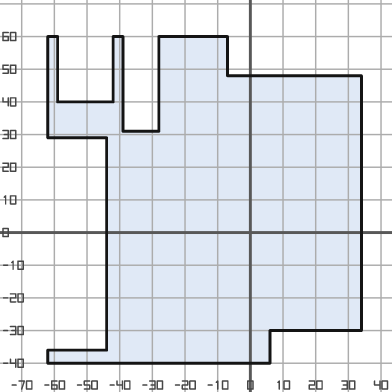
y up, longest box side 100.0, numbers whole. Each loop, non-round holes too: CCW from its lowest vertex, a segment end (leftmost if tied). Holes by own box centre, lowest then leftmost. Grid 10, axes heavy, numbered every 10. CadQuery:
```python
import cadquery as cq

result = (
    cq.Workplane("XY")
    .moveTo(-62.0, -40.0)
    .lineTo(6.0, -40.0)
    .lineTo(6.0, -30.0)
    .lineTo(34.0, -30.0)
    .lineTo(34.0, 48.0)
    .lineTo(-7.0, 48.0)
    .lineTo(-7.0, 60.0)
    .lineTo(-28.0, 60.0)
    .lineTo(-28.0, 31.0)
    .lineTo(-39.0, 31.0)
    .lineTo(-39.0, 60.0)
    .lineTo(-42.0, 60.0)
    .lineTo(-42.0, 40.0)
    .lineTo(-59.0, 40.0)
    .lineTo(-59.0, 60.0)
    .lineTo(-62.0, 60.0)
    .lineTo(-62.0, 29.0)
    .lineTo(-44.0, 29.0)
    .lineTo(-44.0, -36.0)
    .lineTo(-62.0, -36.0)
    .close()
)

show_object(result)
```